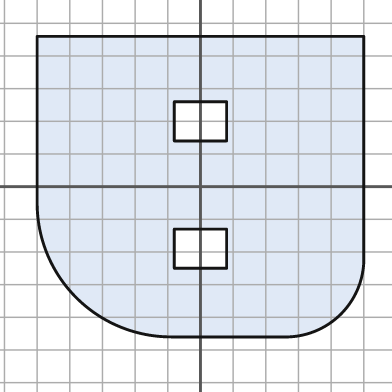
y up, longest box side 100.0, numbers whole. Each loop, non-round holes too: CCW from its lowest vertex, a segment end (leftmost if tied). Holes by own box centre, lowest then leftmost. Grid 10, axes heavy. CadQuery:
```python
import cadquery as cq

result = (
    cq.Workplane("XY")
    .moveTo(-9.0, -46.0)
    .lineTo(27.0, -46.0)
    .threePointArc((43.0, -39.0), (50.0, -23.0))
    .lineTo(50.0, 46.0)
    .lineTo(-50.0, 46.0)
    .lineTo(-50.0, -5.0)
    .threePointArc((-38.0, -34.0), (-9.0, -46.0))
    .close()
    .moveTo(-8.0, -25.0)
    .lineTo(8.0, -25.0)
    .lineTo(8.0, -13.0)
    .lineTo(-8.0, -13.0)
    .close()
    .moveTo(-8.0, 14.0)
    .lineTo(8.0, 14.0)
    .lineTo(8.0, 26.0)
    .lineTo(-8.0, 26.0)
    .close()
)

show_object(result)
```